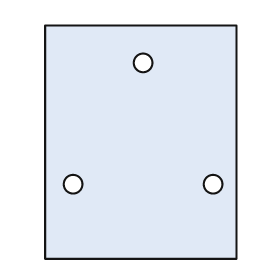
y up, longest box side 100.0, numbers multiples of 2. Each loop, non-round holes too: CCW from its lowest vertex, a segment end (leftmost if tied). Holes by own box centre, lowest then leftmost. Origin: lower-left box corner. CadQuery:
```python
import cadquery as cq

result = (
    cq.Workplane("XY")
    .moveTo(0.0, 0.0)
    .lineTo(82.0, 0.0)
    .lineTo(82.0, 100.0)
    .lineTo(0.0, 100.0)
    .close()
    .moveTo(12.0, 32.0)
    .circle(4.0)
    .moveTo(72.0, 32.0)
    .circle(4.0)
    .moveTo(42.0, 84.0)
    .circle(4.0)
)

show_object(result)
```